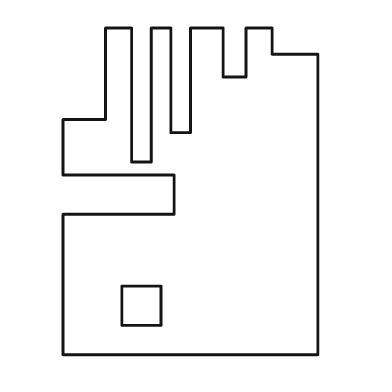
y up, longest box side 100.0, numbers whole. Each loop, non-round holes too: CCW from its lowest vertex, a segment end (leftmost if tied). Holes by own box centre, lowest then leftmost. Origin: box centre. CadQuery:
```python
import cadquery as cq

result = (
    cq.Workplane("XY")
    .moveTo(-39.0, -50.0)
    .lineTo(39.0, -50.0)
    .lineTo(39.0, 42.0)
    .lineTo(25.0, 42.0)
    .lineTo(25.0, 50.0)
    .lineTo(17.0, 50.0)
    .lineTo(17.0, 35.0)
    .lineTo(10.0, 35.0)
    .lineTo(10.0, 50.0)
    .lineTo(0.0, 50.0)
    .lineTo(0.0, 18.0)
    .lineTo(-6.0, 18.0)
    .lineTo(-6.0, 50.0)
    .lineTo(-12.0, 50.0)
    .lineTo(-12.0, 9.0)
    .lineTo(-18.0, 9.0)
    .lineTo(-18.0, 50.0)
    .lineTo(-26.0, 50.0)
    .lineTo(-26.0, 22.0)
    .lineTo(-39.0, 22.0)
    .lineTo(-39.0, 5.0)
    .lineTo(-5.0, 5.0)
    .lineTo(-5.0, -7.0)
    .lineTo(-39.0, -7.0)
    .close()
    .moveTo(-21.0, -41.0)
    .lineTo(-9.0, -41.0)
    .lineTo(-9.0, -29.0)
    .lineTo(-21.0, -29.0)
    .close()
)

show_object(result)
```